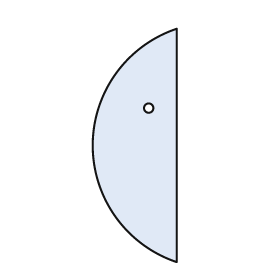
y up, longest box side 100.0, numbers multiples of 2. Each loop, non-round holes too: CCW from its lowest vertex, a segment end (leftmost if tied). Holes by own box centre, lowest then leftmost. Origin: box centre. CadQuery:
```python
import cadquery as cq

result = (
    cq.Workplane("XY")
    .moveTo(18.0, -50.0)
    .lineTo(18.0, 50.0)
    .threePointArc((-18.0, 0.0), (18.0, -50.0))
    .close()
    .moveTo(6.0, 16.0)
    .circle(2.0)
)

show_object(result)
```